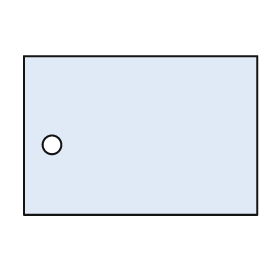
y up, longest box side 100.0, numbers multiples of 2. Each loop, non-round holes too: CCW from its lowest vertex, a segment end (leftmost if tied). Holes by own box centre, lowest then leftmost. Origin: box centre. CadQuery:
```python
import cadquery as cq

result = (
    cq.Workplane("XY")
    .moveTo(-50.0, -34.0)
    .lineTo(50.0, -34.0)
    .lineTo(50.0, 34.0)
    .lineTo(-50.0, 34.0)
    .close()
    .moveTo(-38.0, -4.0)
    .circle(4.0)
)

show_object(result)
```